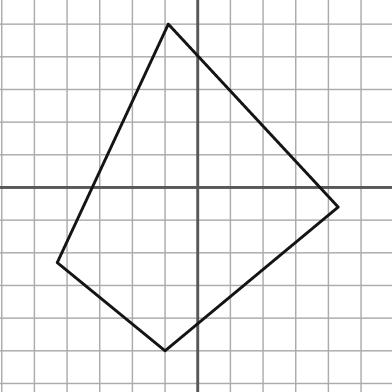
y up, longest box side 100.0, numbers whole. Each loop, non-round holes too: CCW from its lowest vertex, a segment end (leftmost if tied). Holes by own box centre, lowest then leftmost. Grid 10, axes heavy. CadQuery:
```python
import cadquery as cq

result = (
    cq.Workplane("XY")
    .moveTo(-10.0, -50.0)
    .lineTo(43.0, -6.0)
    .lineTo(-9.0, 50.0)
    .lineTo(-43.0, -23.0)
    .close()
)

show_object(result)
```